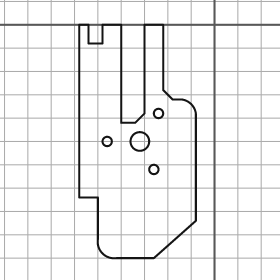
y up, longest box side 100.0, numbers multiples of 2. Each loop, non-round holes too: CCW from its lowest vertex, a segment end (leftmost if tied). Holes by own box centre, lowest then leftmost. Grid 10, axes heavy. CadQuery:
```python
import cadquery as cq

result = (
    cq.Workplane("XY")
    .moveTo(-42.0, -100.0)
    .lineTo(-26.0, -100.0)
    .lineTo(-8.0, -84.0)
    .lineTo(-8.0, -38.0)
    .threePointArc((-10.0, -34.0), (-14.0, -32.0))
    .lineTo(-18.0, -32.0)
    .lineTo(-22.0, -28.0)
    .lineTo(-22.0, 0.0)
    .lineTo(-30.0, 0.0)
    .lineTo(-30.0, -38.0)
    .lineTo(-34.0, -42.0)
    .lineTo(-40.0, -42.0)
    .lineTo(-40.0, 0.0)
    .lineTo(-48.0, 0.0)
    .lineTo(-48.0, -8.0)
    .lineTo(-54.0, -8.0)
    .lineTo(-54.0, 0.0)
    .lineTo(-58.0, 0.0)
    .lineTo(-58.0, -74.0)
    .lineTo(-50.0, -74.0)
    .lineTo(-50.0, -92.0)
    .threePointArc((-48.0, -98.0), (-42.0, -100.0))
    .close()
    .moveTo(-26.0, -62.0)
    .circle(2.0)
    .moveTo(-46.0, -50.0)
    .circle(2.0)
    .moveTo(-32.0, -50.0)
    .circle(4.0)
    .moveTo(-24.0, -38.0)
    .circle(2.0)
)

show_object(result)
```